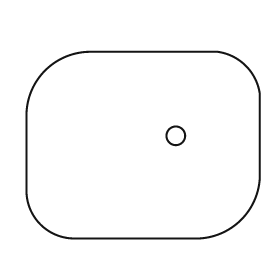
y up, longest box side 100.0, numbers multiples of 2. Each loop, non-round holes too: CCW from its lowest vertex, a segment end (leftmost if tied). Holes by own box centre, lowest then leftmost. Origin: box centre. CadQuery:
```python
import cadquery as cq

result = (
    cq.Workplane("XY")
    .moveTo(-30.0, -40.0)
    .lineTo(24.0, -40.0)
    .threePointArc((42.0, -32.0), (50.0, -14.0))
    .lineTo(50.0, 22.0)
    .threePointArc((44.0, 34.0), (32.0, 40.0))
    .lineTo(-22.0, 40.0)
    .threePointArc((-42.0, 32.0), (-50.0, 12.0))
    .lineTo(-50.0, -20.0)
    .threePointArc((-44.0, -34.0), (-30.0, -40.0))
    .close()
    .moveTo(14.0, 4.0)
    .circle(4.0)
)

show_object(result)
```